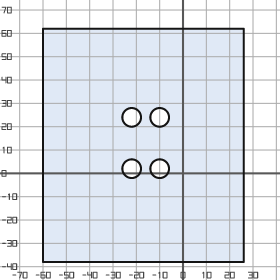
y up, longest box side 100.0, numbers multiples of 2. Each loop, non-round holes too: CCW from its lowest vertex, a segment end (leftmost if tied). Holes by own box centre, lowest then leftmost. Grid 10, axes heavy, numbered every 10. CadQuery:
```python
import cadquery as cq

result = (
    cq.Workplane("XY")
    .moveTo(-60.0, -38.0)
    .lineTo(26.0, -38.0)
    .lineTo(26.0, 62.0)
    .lineTo(-60.0, 62.0)
    .close()
    .moveTo(-22.0, 2.0)
    .circle(4.0)
    .moveTo(-10.0, 2.0)
    .circle(4.0)
    .moveTo(-22.0, 24.0)
    .circle(4.0)
    .moveTo(-10.0, 24.0)
    .circle(4.0)
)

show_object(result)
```